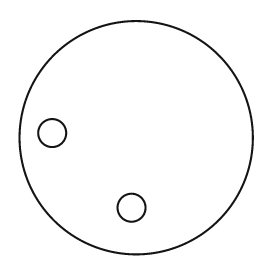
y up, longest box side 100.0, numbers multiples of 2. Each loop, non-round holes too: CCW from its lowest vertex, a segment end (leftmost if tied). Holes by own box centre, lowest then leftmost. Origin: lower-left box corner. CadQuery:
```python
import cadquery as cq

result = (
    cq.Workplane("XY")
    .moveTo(50.0, 50.0)
    .circle(50.0)
    .moveTo(48.0, 20.0)
    .circle(6.0)
    .moveTo(14.0, 52.0)
    .circle(6.0)
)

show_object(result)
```